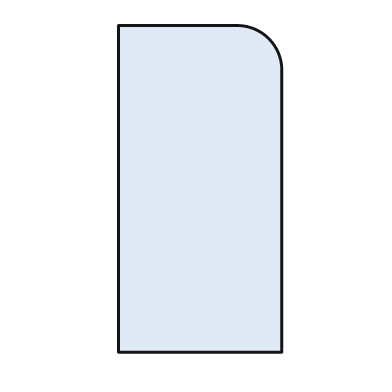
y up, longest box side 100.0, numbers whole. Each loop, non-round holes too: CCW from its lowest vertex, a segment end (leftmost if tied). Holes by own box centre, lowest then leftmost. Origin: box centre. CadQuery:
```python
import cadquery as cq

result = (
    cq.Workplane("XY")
    .moveTo(-25.0, -50.0)
    .lineTo(25.0, -50.0)
    .lineTo(25.0, 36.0)
    .threePointArc((21.0, 46.0), (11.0, 50.0))
    .lineTo(-25.0, 50.0)
    .close()
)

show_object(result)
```